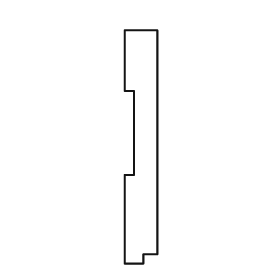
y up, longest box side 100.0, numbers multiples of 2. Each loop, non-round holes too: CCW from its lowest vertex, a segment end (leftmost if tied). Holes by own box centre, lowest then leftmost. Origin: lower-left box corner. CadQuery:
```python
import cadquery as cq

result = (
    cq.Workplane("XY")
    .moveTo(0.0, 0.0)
    .lineTo(8.0, 0.0)
    .lineTo(8.0, 4.0)
    .lineTo(14.0, 4.0)
    .lineTo(14.0, 100.0)
    .lineTo(0.0, 100.0)
    .lineTo(0.0, 74.0)
    .lineTo(4.0, 74.0)
    .lineTo(4.0, 38.0)
    .lineTo(0.0, 38.0)
    .close()
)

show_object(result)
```